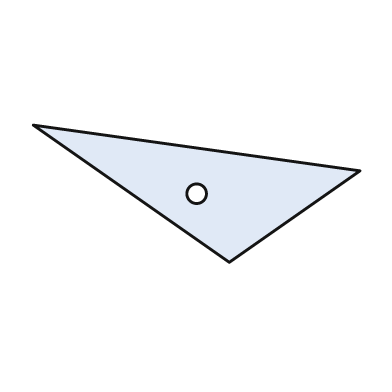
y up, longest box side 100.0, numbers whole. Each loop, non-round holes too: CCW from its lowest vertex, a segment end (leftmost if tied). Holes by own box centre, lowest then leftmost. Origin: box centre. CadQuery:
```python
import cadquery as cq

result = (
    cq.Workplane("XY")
    .moveTo(10.0, -21.0)
    .lineTo(50.0, 7.0)
    .lineTo(-50.0, 21.0)
    .close()
    .moveTo(0.0, 0.0)
    .circle(3.0)
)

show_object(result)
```